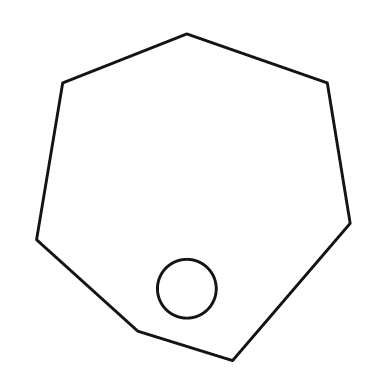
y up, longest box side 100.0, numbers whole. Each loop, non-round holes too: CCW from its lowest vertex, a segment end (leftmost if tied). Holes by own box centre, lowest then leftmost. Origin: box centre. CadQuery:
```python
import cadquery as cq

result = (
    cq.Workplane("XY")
    .moveTo(12.0, -50.0)
    .lineTo(48.0, -8.0)
    .lineTo(41.0, 35.0)
    .lineTo(-2.0, 50.0)
    .lineTo(-40.0, 35.0)
    .lineTo(-48.0, -13.0)
    .lineTo(-17.0, -41.0)
    .close()
    .moveTo(-2.0, -28.0)
    .circle(9.0)
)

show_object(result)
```